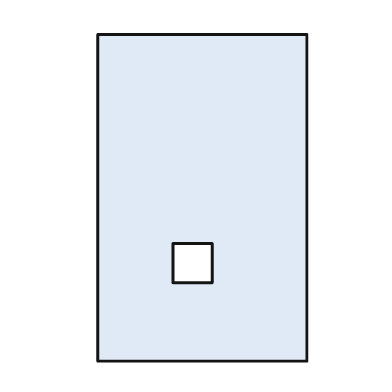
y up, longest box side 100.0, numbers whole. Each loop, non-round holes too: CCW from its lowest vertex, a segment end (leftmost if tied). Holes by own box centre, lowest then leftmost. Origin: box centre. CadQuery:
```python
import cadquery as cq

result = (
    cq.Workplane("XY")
    .moveTo(-32.0, -50.0)
    .lineTo(32.0, -50.0)
    .lineTo(32.0, 50.0)
    .lineTo(-32.0, 50.0)
    .close()
    .moveTo(-9.0, -26.0)
    .lineTo(3.0, -26.0)
    .lineTo(3.0, -14.0)
    .lineTo(-9.0, -14.0)
    .close()
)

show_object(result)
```